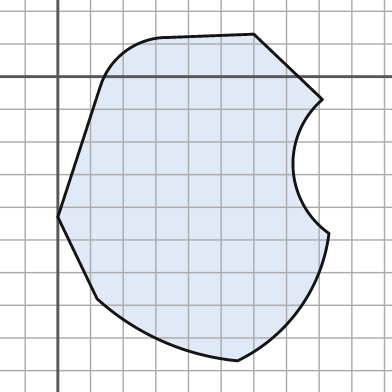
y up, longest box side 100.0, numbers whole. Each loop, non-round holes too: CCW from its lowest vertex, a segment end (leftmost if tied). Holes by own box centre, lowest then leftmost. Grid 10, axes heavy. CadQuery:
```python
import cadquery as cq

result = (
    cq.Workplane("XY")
    .moveTo(55.0, -87.0)
    .threePointArc((74.0, -71.0), (83.0, -48.0))
    .threePointArc((72.0, -28.0), (81.0, -7.0))
    .lineTo(60.0, 13.0)
    .lineTo(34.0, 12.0)
    .threePointArc((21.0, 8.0), (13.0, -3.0))
    .lineTo(0.0, -43.0)
    .lineTo(12.0, -68.0)
    .threePointArc((32.0, -81.0), (55.0, -87.0))
    .close()
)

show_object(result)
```